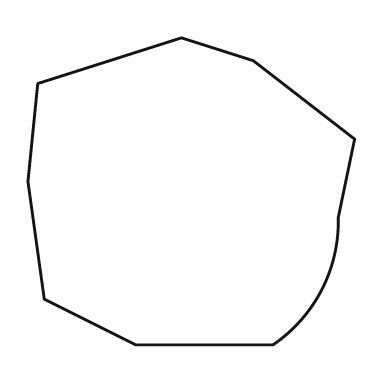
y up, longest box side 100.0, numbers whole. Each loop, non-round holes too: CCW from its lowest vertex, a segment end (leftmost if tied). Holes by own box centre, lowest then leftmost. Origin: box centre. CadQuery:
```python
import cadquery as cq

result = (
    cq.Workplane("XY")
    .moveTo(-17.0, -47.0)
    .lineTo(25.0, -47.0)
    .threePointArc((40.0, -30.0), (45.0, -8.0))
    .lineTo(50.0, 16.0)
    .lineTo(19.0, 40.0)
    .lineTo(-3.0, 47.0)
    .lineTo(-47.0, 33.0)
    .lineTo(-50.0, 3.0)
    .lineTo(-45.0, -33.0)
    .close()
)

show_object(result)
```